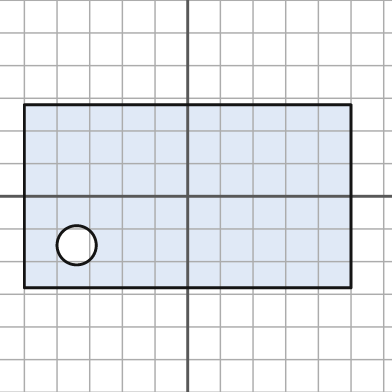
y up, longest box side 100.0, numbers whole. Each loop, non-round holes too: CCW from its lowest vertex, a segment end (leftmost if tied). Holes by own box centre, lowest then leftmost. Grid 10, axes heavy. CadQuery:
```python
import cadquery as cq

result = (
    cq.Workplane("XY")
    .moveTo(-50.0, -28.0)
    .lineTo(50.0, -28.0)
    .lineTo(50.0, 28.0)
    .lineTo(-50.0, 28.0)
    .close()
    .moveTo(-34.0, -15.0)
    .circle(6.0)
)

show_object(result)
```